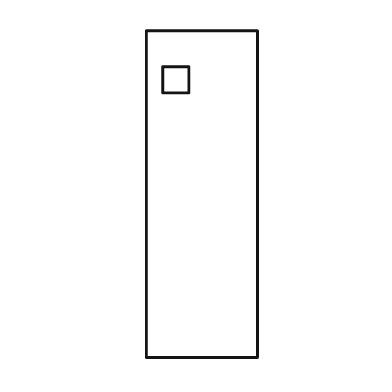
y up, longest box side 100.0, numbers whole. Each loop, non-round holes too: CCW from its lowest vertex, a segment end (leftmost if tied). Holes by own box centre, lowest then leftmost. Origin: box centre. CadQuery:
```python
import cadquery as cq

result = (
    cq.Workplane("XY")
    .moveTo(-17.0, -50.0)
    .lineTo(17.0, -50.0)
    .lineTo(17.0, 50.0)
    .lineTo(-17.0, 50.0)
    .close()
    .moveTo(-12.0, 31.0)
    .lineTo(-4.0, 31.0)
    .lineTo(-4.0, 39.0)
    .lineTo(-12.0, 39.0)
    .close()
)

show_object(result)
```